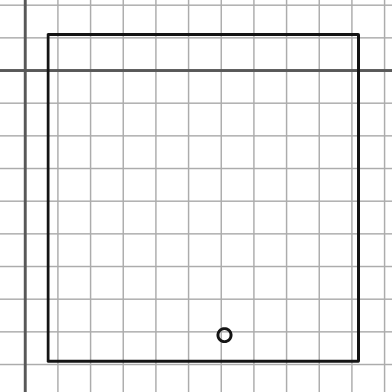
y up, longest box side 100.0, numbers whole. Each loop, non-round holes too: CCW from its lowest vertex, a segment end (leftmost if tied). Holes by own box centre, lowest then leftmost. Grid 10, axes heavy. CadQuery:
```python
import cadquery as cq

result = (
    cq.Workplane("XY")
    .moveTo(7.0, -89.0)
    .lineTo(102.0, -89.0)
    .lineTo(102.0, 11.0)
    .lineTo(7.0, 11.0)
    .close()
    .moveTo(61.0, -81.0)
    .circle(2.0)
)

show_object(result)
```